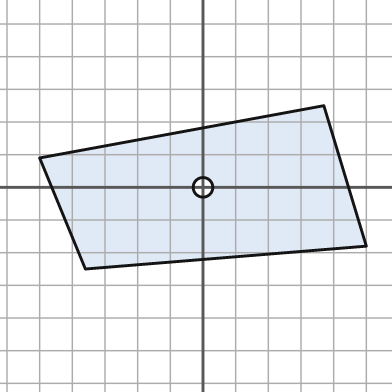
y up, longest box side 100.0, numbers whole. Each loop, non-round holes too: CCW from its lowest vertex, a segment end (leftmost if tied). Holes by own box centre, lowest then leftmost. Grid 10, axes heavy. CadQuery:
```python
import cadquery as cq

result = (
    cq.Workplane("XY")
    .moveTo(-36.0, -25.0)
    .lineTo(50.0, -18.0)
    .lineTo(37.0, 25.0)
    .lineTo(-50.0, 9.0)
    .close()
    .moveTo(0.0, 0.0)
    .circle(3.0)
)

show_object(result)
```